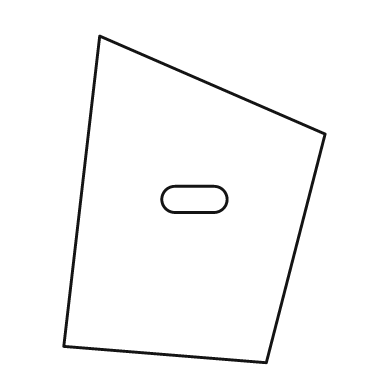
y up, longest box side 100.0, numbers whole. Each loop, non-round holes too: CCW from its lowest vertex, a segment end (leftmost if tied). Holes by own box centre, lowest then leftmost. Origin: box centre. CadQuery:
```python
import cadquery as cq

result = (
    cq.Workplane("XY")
    .moveTo(22.0, -50.0)
    .lineTo(40.0, 20.0)
    .lineTo(-29.0, 50.0)
    .lineTo(-40.0, -45.0)
    .close()
    .moveTo(-6.0, -4.0)
    .lineTo(6.0, -4.0)
    .threePointArc((10.0, 0.0), (6.0, 4.0))
    .lineTo(-6.0, 4.0)
    .threePointArc((-10.0, 0.0), (-6.0, -4.0))
    .close()
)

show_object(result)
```